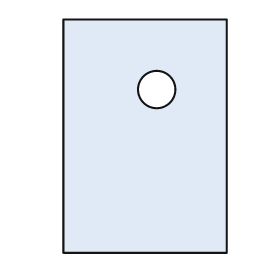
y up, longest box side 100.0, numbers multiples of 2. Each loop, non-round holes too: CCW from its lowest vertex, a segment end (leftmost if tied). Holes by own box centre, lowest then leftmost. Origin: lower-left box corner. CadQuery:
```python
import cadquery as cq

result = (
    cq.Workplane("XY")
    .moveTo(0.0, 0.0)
    .lineTo(70.0, 0.0)
    .lineTo(70.0, 100.0)
    .lineTo(0.0, 100.0)
    .close()
    .moveTo(40.0, 70.0)
    .circle(8.0)
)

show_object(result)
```